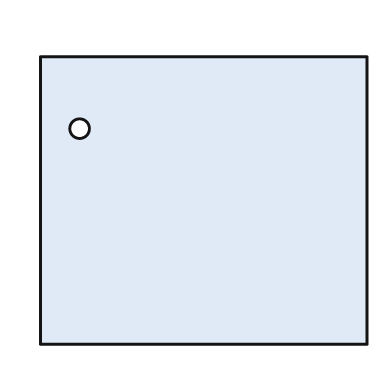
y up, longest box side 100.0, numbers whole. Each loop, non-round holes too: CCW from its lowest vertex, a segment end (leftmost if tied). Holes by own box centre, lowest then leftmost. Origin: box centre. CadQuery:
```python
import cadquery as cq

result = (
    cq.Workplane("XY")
    .moveTo(-50.0, -44.0)
    .lineTo(50.0, -44.0)
    .lineTo(50.0, 44.0)
    .lineTo(-50.0, 44.0)
    .close()
    .moveTo(-38.0, 22.0)
    .circle(3.0)
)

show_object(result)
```